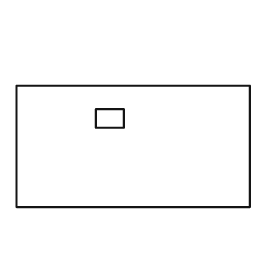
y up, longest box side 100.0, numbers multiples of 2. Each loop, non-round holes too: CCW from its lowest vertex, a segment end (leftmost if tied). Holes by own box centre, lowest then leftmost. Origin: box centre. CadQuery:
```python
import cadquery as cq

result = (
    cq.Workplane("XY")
    .moveTo(-50.0, -26.0)
    .lineTo(50.0, -26.0)
    .lineTo(50.0, 26.0)
    .lineTo(-50.0, 26.0)
    .close()
    .moveTo(-16.0, 8.0)
    .lineTo(-4.0, 8.0)
    .lineTo(-4.0, 16.0)
    .lineTo(-16.0, 16.0)
    .close()
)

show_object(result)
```